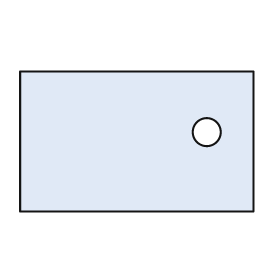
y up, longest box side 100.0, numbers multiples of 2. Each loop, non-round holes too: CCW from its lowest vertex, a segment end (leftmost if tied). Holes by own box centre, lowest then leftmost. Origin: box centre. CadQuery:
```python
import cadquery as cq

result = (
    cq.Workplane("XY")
    .moveTo(-50.0, -30.0)
    .lineTo(50.0, -30.0)
    .lineTo(50.0, 30.0)
    .lineTo(-50.0, 30.0)
    .close()
    .moveTo(30.0, 4.0)
    .circle(6.0)
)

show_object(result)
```